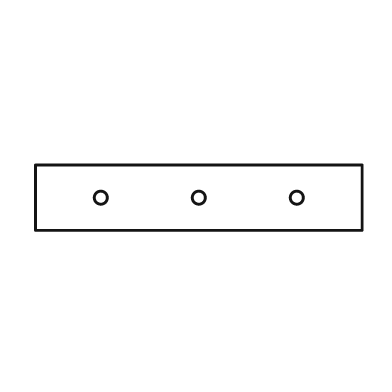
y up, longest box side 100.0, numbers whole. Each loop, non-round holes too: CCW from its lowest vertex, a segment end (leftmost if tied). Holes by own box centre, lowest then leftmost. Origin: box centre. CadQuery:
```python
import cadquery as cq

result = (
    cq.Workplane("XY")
    .moveTo(-50.0, -10.0)
    .lineTo(50.0, -10.0)
    .lineTo(50.0, 10.0)
    .lineTo(-50.0, 10.0)
    .close()
    .moveTo(-30.0, 0.0)
    .circle(2.0)
    .moveTo(0.0, 0.0)
    .circle(2.0)
    .moveTo(30.0, 0.0)
    .circle(2.0)
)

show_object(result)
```